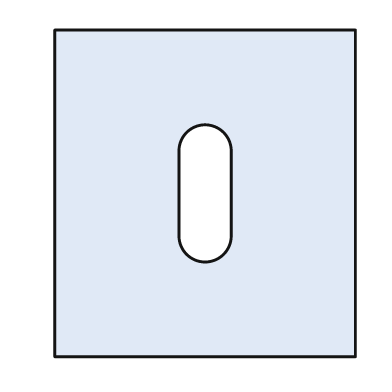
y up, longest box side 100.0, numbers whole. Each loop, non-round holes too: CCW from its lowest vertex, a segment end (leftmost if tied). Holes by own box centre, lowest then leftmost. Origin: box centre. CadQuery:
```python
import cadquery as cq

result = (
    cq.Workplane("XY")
    .moveTo(-46.0, -50.0)
    .lineTo(46.0, -50.0)
    .lineTo(46.0, 50.0)
    .lineTo(-46.0, 50.0)
    .close()
    .moveTo(-8.0, -13.0)
    .threePointArc((0.0, -21.0), (8.0, -13.0))
    .lineTo(8.0, 13.0)
    .threePointArc((0.0, 21.0), (-8.0, 13.0))
    .close()
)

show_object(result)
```